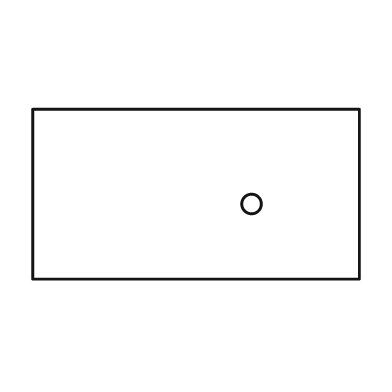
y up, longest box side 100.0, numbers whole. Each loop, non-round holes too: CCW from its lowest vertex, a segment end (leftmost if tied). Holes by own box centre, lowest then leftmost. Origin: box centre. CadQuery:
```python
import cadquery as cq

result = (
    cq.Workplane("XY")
    .moveTo(-50.0, -26.0)
    .lineTo(50.0, -26.0)
    .lineTo(50.0, 26.0)
    .lineTo(-50.0, 26.0)
    .close()
    .moveTo(17.0, -3.0)
    .circle(3.0)
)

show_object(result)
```